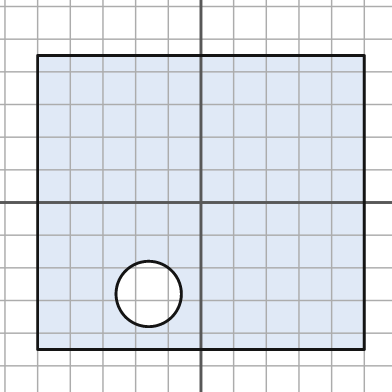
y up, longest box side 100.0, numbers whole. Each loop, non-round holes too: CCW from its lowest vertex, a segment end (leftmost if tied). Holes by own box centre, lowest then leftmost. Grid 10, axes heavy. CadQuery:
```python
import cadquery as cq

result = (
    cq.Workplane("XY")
    .moveTo(-50.0, -45.0)
    .lineTo(50.0, -45.0)
    .lineTo(50.0, 45.0)
    .lineTo(-50.0, 45.0)
    .close()
    .moveTo(-16.0, -28.0)
    .circle(10.0)
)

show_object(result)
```